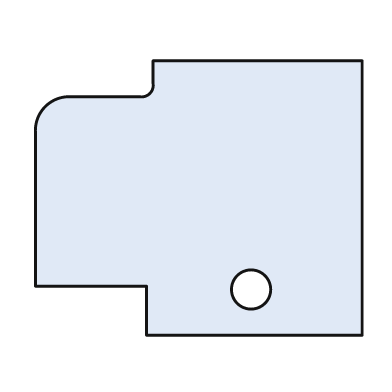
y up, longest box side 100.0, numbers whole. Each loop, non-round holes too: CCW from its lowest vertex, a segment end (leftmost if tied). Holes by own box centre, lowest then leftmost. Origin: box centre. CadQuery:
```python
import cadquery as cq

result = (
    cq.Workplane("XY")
    .moveTo(-16.0, -42.0)
    .lineTo(50.0, -42.0)
    .lineTo(50.0, 42.0)
    .lineTo(-14.0, 42.0)
    .lineTo(-14.0, 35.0)
    .threePointArc((-15.0, 32.0), (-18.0, 31.0))
    .lineTo(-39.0, 31.0)
    .threePointArc((-47.0, 28.0), (-50.0, 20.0))
    .lineTo(-50.0, -27.0)
    .lineTo(-16.0, -27.0)
    .close()
    .moveTo(16.0, -28.0)
    .circle(6.0)
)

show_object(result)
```